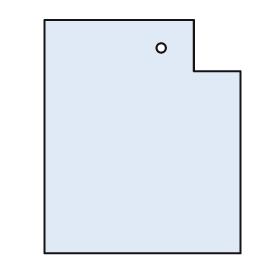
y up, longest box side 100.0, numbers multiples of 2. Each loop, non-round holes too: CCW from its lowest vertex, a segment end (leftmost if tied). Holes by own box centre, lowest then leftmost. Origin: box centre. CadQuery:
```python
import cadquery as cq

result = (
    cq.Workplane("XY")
    .moveTo(-42.0, -50.0)
    .lineTo(42.0, -50.0)
    .lineTo(42.0, 28.0)
    .lineTo(22.0, 28.0)
    .lineTo(22.0, 50.0)
    .lineTo(-42.0, 50.0)
    .close()
    .moveTo(8.0, 38.0)
    .circle(2.0)
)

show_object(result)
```